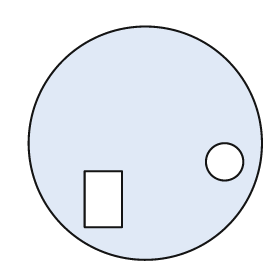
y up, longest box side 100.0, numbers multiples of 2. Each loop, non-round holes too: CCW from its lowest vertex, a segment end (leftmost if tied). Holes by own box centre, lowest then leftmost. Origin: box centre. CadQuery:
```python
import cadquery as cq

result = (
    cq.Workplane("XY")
    .moveTo(0.0, 0.0)
    .circle(50.0)
    .moveTo(-26.0, -36.0)
    .lineTo(-10.0, -36.0)
    .lineTo(-10.0, -12.0)
    .lineTo(-26.0, -12.0)
    .close()
    .moveTo(34.0, -8.0)
    .circle(8.0)
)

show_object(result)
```